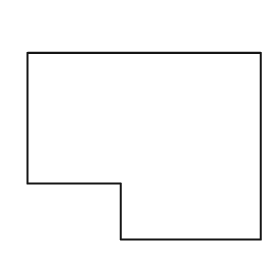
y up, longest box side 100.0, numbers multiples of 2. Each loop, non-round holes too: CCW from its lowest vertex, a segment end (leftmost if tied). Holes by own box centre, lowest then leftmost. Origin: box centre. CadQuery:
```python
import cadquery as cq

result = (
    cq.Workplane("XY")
    .moveTo(-10.0, -40.0)
    .lineTo(50.0, -40.0)
    .lineTo(50.0, 40.0)
    .lineTo(-50.0, 40.0)
    .lineTo(-50.0, -16.0)
    .lineTo(-10.0, -16.0)
    .close()
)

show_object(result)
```